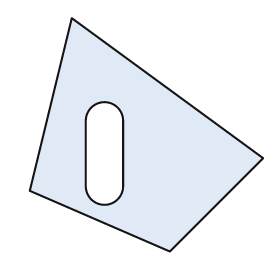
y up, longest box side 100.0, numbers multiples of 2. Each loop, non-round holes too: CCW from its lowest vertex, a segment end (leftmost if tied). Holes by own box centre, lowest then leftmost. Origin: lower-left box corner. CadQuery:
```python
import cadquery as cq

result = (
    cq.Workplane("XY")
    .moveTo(60.0, 0.0)
    .lineTo(100.0, 40.0)
    .lineTo(18.0, 100.0)
    .lineTo(0.0, 26.0)
    .close()
    .moveTo(24.0, 28.0)
    .threePointArc((32.0, 20.0), (40.0, 28.0))
    .lineTo(40.0, 56.0)
    .threePointArc((32.0, 64.0), (24.0, 56.0))
    .close()
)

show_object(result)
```